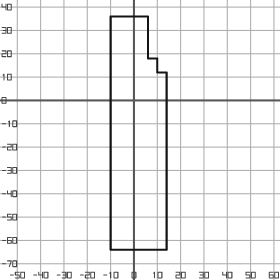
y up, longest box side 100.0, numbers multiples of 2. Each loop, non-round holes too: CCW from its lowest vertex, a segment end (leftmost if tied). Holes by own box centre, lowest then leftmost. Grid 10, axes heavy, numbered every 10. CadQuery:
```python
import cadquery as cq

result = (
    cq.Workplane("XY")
    .moveTo(-10.0, -64.0)
    .lineTo(14.0, -64.0)
    .lineTo(14.0, 12.0)
    .lineTo(10.0, 12.0)
    .lineTo(10.0, 18.0)
    .lineTo(6.0, 18.0)
    .lineTo(6.0, 36.0)
    .lineTo(-10.0, 36.0)
    .close()
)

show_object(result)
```